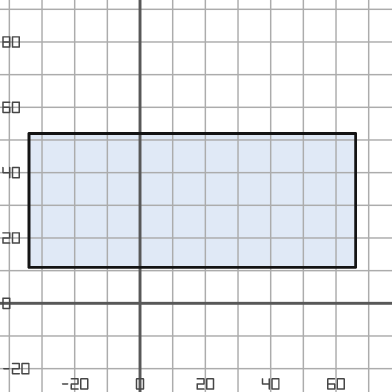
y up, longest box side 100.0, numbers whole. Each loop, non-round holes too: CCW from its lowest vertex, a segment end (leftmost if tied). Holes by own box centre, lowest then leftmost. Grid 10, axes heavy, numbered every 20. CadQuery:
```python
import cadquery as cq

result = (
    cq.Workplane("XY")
    .moveTo(-34.0, 11.0)
    .lineTo(66.0, 11.0)
    .lineTo(66.0, 52.0)
    .lineTo(-34.0, 52.0)
    .close()
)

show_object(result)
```